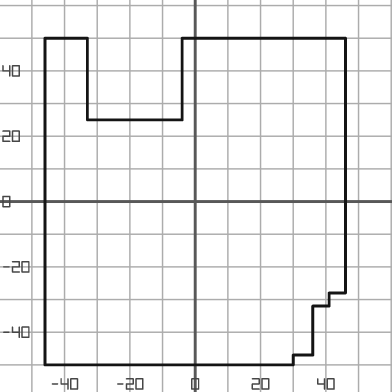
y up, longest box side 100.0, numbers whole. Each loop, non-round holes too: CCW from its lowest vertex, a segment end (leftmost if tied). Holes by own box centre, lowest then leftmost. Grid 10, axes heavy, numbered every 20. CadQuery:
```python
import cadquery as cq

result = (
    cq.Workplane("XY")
    .moveTo(-46.0, -50.0)
    .lineTo(30.0, -50.0)
    .lineTo(30.0, -47.0)
    .lineTo(36.0, -47.0)
    .lineTo(36.0, -32.0)
    .lineTo(41.0, -32.0)
    .lineTo(41.0, -28.0)
    .lineTo(46.0, -28.0)
    .lineTo(46.0, 50.0)
    .lineTo(-4.0, 50.0)
    .lineTo(-4.0, 25.0)
    .lineTo(-33.0, 25.0)
    .lineTo(-33.0, 50.0)
    .lineTo(-46.0, 50.0)
    .close()
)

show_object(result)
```